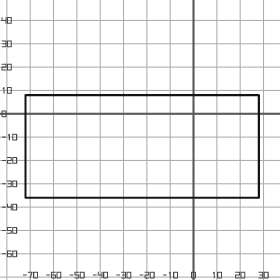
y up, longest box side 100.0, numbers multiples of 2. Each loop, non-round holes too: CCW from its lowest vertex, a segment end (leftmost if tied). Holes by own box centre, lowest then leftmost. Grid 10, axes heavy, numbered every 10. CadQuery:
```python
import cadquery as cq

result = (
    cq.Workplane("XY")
    .moveTo(-72.0, -36.0)
    .lineTo(28.0, -36.0)
    .lineTo(28.0, 8.0)
    .lineTo(-72.0, 8.0)
    .close()
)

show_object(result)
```